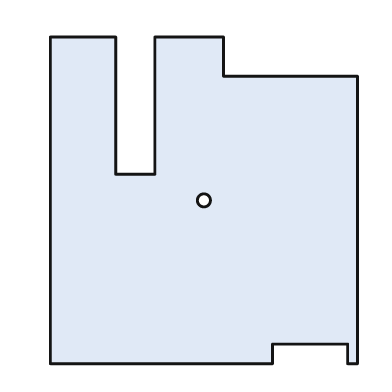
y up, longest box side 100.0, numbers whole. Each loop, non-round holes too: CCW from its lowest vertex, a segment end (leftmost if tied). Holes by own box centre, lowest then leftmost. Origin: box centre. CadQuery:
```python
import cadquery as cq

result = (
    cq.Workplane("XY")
    .moveTo(-47.0, -50.0)
    .lineTo(21.0, -50.0)
    .lineTo(21.0, -44.0)
    .lineTo(44.0, -44.0)
    .lineTo(44.0, -50.0)
    .lineTo(47.0, -50.0)
    .lineTo(47.0, 38.0)
    .lineTo(6.0, 38.0)
    .lineTo(6.0, 50.0)
    .lineTo(-15.0, 50.0)
    .lineTo(-15.0, 8.0)
    .lineTo(-27.0, 8.0)
    .lineTo(-27.0, 50.0)
    .lineTo(-47.0, 50.0)
    .close()
    .moveTo(0.0, 0.0)
    .circle(2.0)
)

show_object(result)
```